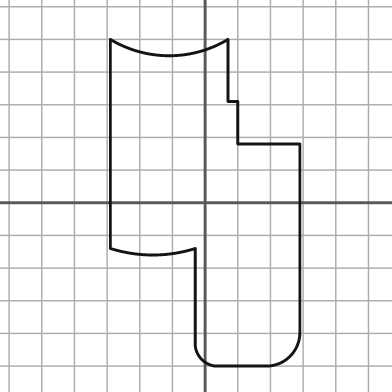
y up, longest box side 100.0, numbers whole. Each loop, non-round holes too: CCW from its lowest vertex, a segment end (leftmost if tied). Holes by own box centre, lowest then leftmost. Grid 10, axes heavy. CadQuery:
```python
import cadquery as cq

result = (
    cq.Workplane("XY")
    .moveTo(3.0, -50.0)
    .lineTo(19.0, -50.0)
    .threePointArc((26.0, -47.0), (29.0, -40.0))
    .lineTo(29.0, 18.0)
    .lineTo(10.0, 18.0)
    .lineTo(10.0, 31.0)
    .lineTo(7.0, 31.0)
    .lineTo(7.0, 50.0)
    .threePointArc((-11.0, 45.0), (-29.0, 50.0))
    .lineTo(-29.0, -14.0)
    .threePointArc((-16.0, -16.0), (-3.0, -14.0))
    .lineTo(-3.0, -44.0)
    .threePointArc((-1.0, -48.0), (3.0, -50.0))
    .close()
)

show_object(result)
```